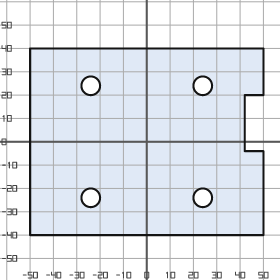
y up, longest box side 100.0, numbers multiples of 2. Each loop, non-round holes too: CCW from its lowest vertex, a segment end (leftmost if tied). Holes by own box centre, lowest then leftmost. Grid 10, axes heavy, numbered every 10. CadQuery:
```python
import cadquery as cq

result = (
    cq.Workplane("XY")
    .moveTo(-50.0, -40.0)
    .lineTo(50.0, -40.0)
    .lineTo(50.0, -4.0)
    .lineTo(42.0, -4.0)
    .lineTo(42.0, 20.0)
    .lineTo(50.0, 20.0)
    .lineTo(50.0, 40.0)
    .lineTo(-50.0, 40.0)
    .close()
    .moveTo(-24.0, -24.0)
    .circle(4.0)
    .moveTo(24.0, -24.0)
    .circle(4.0)
    .moveTo(-24.0, 24.0)
    .circle(4.0)
    .moveTo(24.0, 24.0)
    .circle(4.0)
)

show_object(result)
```